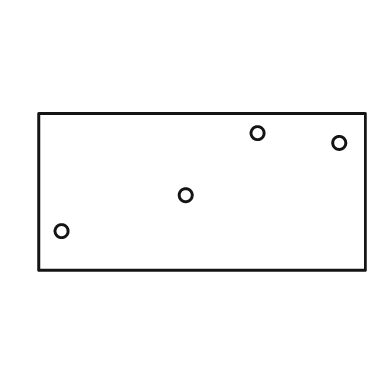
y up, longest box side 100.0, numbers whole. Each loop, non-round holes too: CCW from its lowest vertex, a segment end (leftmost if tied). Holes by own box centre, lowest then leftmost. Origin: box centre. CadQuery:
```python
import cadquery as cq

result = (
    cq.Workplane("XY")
    .moveTo(-50.0, -24.0)
    .lineTo(50.0, -24.0)
    .lineTo(50.0, 24.0)
    .lineTo(-50.0, 24.0)
    .close()
    .moveTo(-43.0, -12.0)
    .circle(2.0)
    .moveTo(-5.0, -1.0)
    .circle(2.0)
    .moveTo(42.0, 15.0)
    .circle(2.0)
    .moveTo(17.0, 18.0)
    .circle(2.0)
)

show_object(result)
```